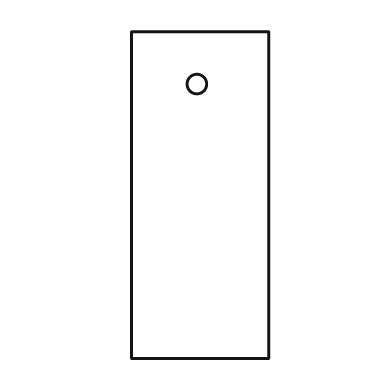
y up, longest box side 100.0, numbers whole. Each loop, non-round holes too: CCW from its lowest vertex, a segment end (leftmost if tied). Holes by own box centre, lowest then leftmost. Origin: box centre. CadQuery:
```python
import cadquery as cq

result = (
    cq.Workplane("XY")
    .moveTo(-21.0, -50.0)
    .lineTo(21.0, -50.0)
    .lineTo(21.0, 50.0)
    .lineTo(-21.0, 50.0)
    .close()
    .moveTo(-1.0, 34.0)
    .circle(3.0)
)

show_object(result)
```